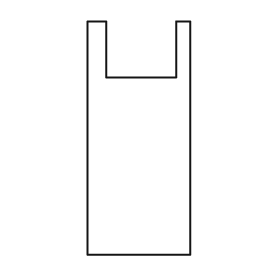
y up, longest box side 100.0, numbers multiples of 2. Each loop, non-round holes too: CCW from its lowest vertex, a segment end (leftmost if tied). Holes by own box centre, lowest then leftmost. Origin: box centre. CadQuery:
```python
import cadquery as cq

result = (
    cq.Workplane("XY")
    .moveTo(-22.0, -50.0)
    .lineTo(22.0, -50.0)
    .lineTo(22.0, 50.0)
    .lineTo(16.0, 50.0)
    .lineTo(16.0, 26.0)
    .lineTo(-14.0, 26.0)
    .lineTo(-14.0, 50.0)
    .lineTo(-22.0, 50.0)
    .close()
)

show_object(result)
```